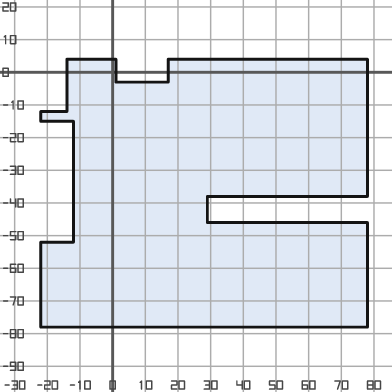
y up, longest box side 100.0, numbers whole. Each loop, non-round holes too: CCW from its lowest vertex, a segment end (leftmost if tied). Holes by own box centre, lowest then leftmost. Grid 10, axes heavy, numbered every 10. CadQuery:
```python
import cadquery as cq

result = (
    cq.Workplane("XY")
    .moveTo(-22.0, -78.0)
    .lineTo(78.0, -78.0)
    .lineTo(78.0, -46.0)
    .lineTo(29.0, -46.0)
    .lineTo(29.0, -38.0)
    .lineTo(78.0, -38.0)
    .lineTo(78.0, 4.0)
    .lineTo(17.0, 4.0)
    .lineTo(17.0, -3.0)
    .lineTo(1.0, -3.0)
    .lineTo(1.0, 4.0)
    .lineTo(-14.0, 4.0)
    .lineTo(-14.0, -12.0)
    .lineTo(-22.0, -12.0)
    .lineTo(-22.0, -15.0)
    .lineTo(-12.0, -15.0)
    .lineTo(-12.0, -52.0)
    .lineTo(-22.0, -52.0)
    .close()
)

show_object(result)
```